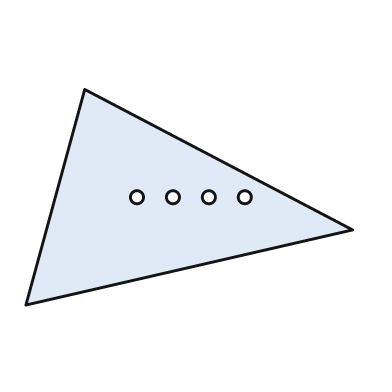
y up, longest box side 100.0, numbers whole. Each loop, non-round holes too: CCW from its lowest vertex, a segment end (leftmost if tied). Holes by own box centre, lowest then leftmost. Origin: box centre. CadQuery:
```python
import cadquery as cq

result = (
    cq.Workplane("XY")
    .moveTo(-50.0, -33.0)
    .lineTo(50.0, -10.0)
    .lineTo(-32.0, 33.0)
    .close()
    .moveTo(-16.0, 0.0)
    .circle(2.0)
    .moveTo(-5.0, 0.0)
    .circle(2.0)
    .moveTo(6.0, 0.0)
    .circle(2.0)
    .moveTo(17.0, 0.0)
    .circle(2.0)
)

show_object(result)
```